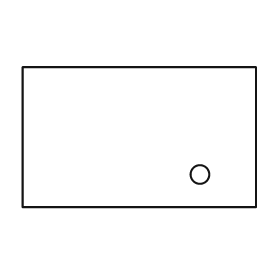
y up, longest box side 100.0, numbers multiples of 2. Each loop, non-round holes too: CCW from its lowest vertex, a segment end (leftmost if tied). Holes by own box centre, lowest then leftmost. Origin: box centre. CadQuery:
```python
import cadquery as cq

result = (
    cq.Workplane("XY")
    .moveTo(-50.0, -30.0)
    .lineTo(50.0, -30.0)
    .lineTo(50.0, 30.0)
    .lineTo(-50.0, 30.0)
    .close()
    .moveTo(26.0, -16.0)
    .circle(4.0)
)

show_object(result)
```